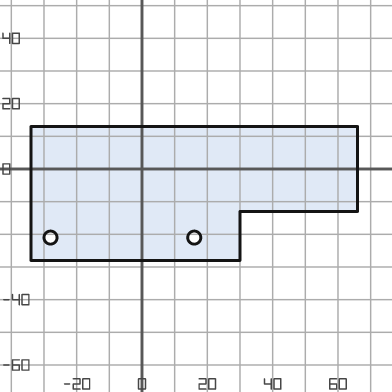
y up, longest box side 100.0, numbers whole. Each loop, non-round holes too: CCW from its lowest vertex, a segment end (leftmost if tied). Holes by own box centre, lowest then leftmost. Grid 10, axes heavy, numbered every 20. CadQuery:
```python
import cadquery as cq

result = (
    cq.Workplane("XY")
    .moveTo(-34.0, -28.0)
    .lineTo(30.0, -28.0)
    .lineTo(30.0, -13.0)
    .lineTo(66.0, -13.0)
    .lineTo(66.0, 13.0)
    .lineTo(-34.0, 13.0)
    .close()
    .moveTo(-28.0, -21.0)
    .circle(2.0)
    .moveTo(16.0, -21.0)
    .circle(2.0)
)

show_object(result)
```